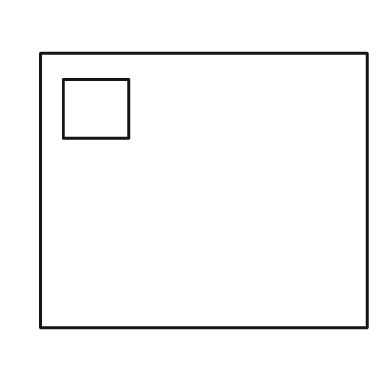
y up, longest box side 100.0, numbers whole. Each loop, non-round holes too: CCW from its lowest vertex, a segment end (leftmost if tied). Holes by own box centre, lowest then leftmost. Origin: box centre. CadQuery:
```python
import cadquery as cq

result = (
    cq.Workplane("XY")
    .moveTo(-50.0, -42.0)
    .lineTo(50.0, -42.0)
    .lineTo(50.0, 42.0)
    .lineTo(-50.0, 42.0)
    .close()
    .moveTo(-43.0, 16.0)
    .lineTo(-23.0, 16.0)
    .lineTo(-23.0, 34.0)
    .lineTo(-43.0, 34.0)
    .close()
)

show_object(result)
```